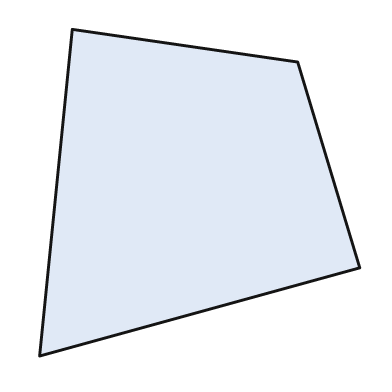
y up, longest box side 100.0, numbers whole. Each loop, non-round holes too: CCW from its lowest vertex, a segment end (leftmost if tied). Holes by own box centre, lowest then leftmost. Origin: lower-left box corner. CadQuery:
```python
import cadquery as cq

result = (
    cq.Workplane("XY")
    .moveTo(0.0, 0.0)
    .lineTo(98.0, 27.0)
    .lineTo(79.0, 90.0)
    .lineTo(10.0, 100.0)
    .close()
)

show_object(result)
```